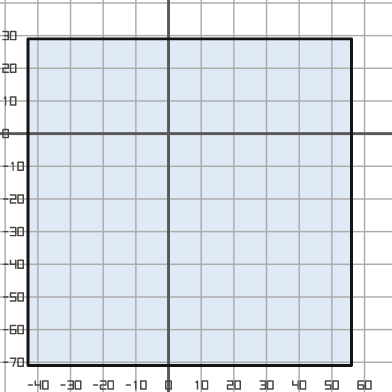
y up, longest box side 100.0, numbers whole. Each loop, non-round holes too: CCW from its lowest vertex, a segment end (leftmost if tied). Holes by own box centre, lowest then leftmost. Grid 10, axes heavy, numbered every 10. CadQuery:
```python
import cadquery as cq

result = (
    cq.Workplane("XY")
    .moveTo(-43.0, -71.0)
    .lineTo(56.0, -71.0)
    .lineTo(56.0, 29.0)
    .lineTo(-43.0, 29.0)
    .close()
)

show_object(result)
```